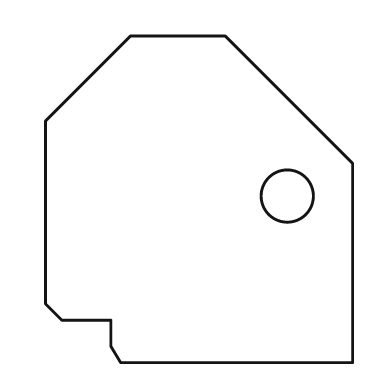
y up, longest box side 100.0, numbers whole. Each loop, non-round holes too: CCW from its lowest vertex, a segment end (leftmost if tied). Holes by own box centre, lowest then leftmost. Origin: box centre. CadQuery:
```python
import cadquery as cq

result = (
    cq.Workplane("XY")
    .moveTo(-24.0, -50.0)
    .lineTo(47.0, -50.0)
    .lineTo(47.0, 11.0)
    .lineTo(8.0, 50.0)
    .lineTo(-21.0, 50.0)
    .lineTo(-47.0, 24.0)
    .lineTo(-47.0, -32.0)
    .lineTo(-42.0, -37.0)
    .lineTo(-27.0, -37.0)
    .lineTo(-27.0, -45.0)
    .close()
    .moveTo(27.0, 1.0)
    .circle(8.0)
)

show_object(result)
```